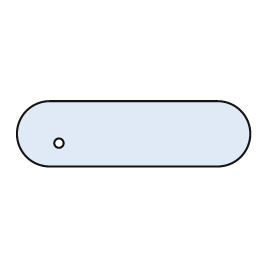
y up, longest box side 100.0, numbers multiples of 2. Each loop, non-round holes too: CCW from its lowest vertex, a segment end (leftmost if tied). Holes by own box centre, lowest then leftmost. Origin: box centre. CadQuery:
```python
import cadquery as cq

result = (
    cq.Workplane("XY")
    .moveTo(-36.0, -14.0)
    .lineTo(36.0, -14.0)
    .threePointArc((50.0, 0.0), (36.0, 14.0))
    .lineTo(-36.0, 14.0)
    .threePointArc((-50.0, 0.0), (-36.0, -14.0))
    .close()
    .moveTo(-32.0, -4.0)
    .circle(2.0)
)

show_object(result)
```